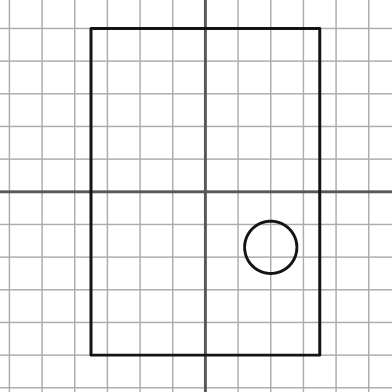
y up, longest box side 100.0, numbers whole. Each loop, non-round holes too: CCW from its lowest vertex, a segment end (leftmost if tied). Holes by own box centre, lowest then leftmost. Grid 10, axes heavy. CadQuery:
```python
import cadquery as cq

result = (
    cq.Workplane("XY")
    .moveTo(-35.0, -50.0)
    .lineTo(35.0, -50.0)
    .lineTo(35.0, 50.0)
    .lineTo(-35.0, 50.0)
    .close()
    .moveTo(20.0, -17.0)
    .circle(8.0)
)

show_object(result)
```